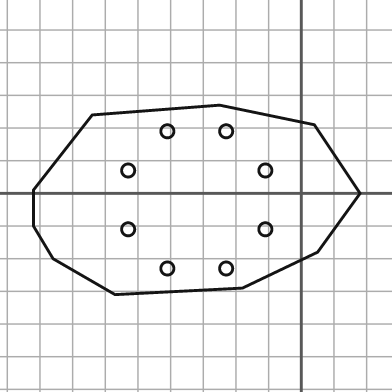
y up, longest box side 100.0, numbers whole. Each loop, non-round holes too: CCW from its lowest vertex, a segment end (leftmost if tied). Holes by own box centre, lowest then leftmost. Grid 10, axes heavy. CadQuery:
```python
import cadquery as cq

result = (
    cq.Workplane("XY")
    .moveTo(-57.0, -31.0)
    .lineTo(-18.0, -29.0)
    .lineTo(5.0, -18.0)
    .lineTo(18.0, 0.0)
    .lineTo(4.0, 21.0)
    .lineTo(-25.0, 27.0)
    .lineTo(-64.0, 24.0)
    .lineTo(-82.0, 1.0)
    .lineTo(-82.0, -10.0)
    .lineTo(-76.0, -20.0)
    .close()
    .moveTo(-41.0, -23.0)
    .circle(2.0)
    .moveTo(-23.0, -23.0)
    .circle(2.0)
    .moveTo(-53.0, -11.0)
    .circle(2.0)
    .moveTo(-11.0, -11.0)
    .circle(2.0)
    .moveTo(-53.0, 7.0)
    .circle(2.0)
    .moveTo(-11.0, 7.0)
    .circle(2.0)
    .moveTo(-41.0, 19.0)
    .circle(2.0)
    .moveTo(-23.0, 19.0)
    .circle(2.0)
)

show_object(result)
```